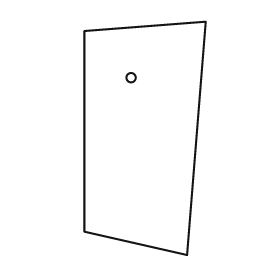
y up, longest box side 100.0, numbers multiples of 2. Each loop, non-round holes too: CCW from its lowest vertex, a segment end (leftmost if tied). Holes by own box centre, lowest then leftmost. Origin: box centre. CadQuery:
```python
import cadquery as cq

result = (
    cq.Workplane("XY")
    .moveTo(18.0, -50.0)
    .lineTo(26.0, 50.0)
    .lineTo(-26.0, 46.0)
    .lineTo(-26.0, -40.0)
    .close()
    .moveTo(-6.0, 26.0)
    .circle(2.0)
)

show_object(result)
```